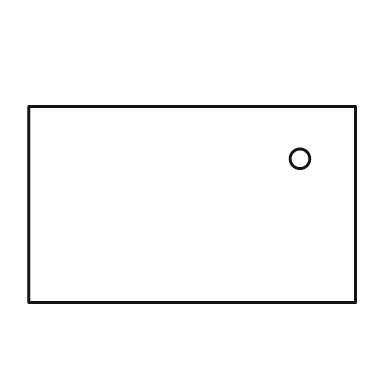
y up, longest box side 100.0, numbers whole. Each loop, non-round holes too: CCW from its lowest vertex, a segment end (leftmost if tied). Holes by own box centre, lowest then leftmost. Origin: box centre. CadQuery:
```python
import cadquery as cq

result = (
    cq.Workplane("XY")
    .moveTo(-50.0, -30.0)
    .lineTo(50.0, -30.0)
    .lineTo(50.0, 30.0)
    .lineTo(-50.0, 30.0)
    .close()
    .moveTo(33.0, 14.0)
    .circle(3.0)
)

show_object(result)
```